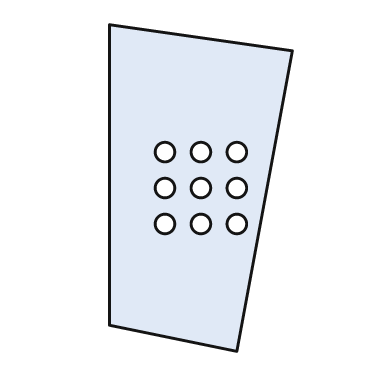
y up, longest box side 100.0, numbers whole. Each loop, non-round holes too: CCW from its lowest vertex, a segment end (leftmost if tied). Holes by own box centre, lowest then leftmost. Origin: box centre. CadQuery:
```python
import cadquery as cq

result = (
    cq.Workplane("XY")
    .moveTo(11.0, -50.0)
    .lineTo(28.0, 42.0)
    .lineTo(-28.0, 50.0)
    .lineTo(-28.0, -42.0)
    .close()
    .moveTo(-11.0, -11.0)
    .circle(3.0)
    .moveTo(0.0, -11.0)
    .circle(3.0)
    .moveTo(11.0, -11.0)
    .circle(3.0)
    .moveTo(-11.0, 0.0)
    .circle(3.0)
    .moveTo(0.0, 0.0)
    .circle(3.0)
    .moveTo(11.0, 0.0)
    .circle(3.0)
    .moveTo(-11.0, 11.0)
    .circle(3.0)
    .moveTo(0.0, 11.0)
    .circle(3.0)
    .moveTo(11.0, 11.0)
    .circle(3.0)
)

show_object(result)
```